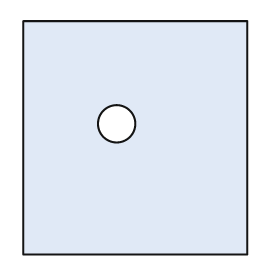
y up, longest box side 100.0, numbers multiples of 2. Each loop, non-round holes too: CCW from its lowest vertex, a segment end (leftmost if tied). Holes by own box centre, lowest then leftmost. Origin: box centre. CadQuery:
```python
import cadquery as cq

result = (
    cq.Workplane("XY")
    .moveTo(-48.0, -50.0)
    .lineTo(48.0, -50.0)
    .lineTo(48.0, 50.0)
    .lineTo(-48.0, 50.0)
    .close()
    .moveTo(-8.0, 6.0)
    .circle(8.0)
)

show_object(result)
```